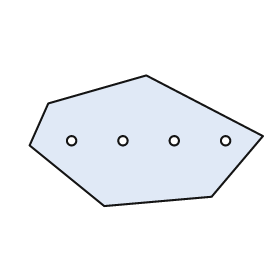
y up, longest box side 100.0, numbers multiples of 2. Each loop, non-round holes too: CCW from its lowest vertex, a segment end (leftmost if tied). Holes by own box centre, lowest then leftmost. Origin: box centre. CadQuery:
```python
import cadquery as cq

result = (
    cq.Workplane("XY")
    .moveTo(-18.0, -28.0)
    .lineTo(28.0, -24.0)
    .lineTo(50.0, 2.0)
    .lineTo(0.0, 28.0)
    .lineTo(-42.0, 16.0)
    .lineTo(-50.0, -2.0)
    .close()
    .moveTo(-32.0, 0.0)
    .circle(2.0)
    .moveTo(-10.0, 0.0)
    .circle(2.0)
    .moveTo(12.0, 0.0)
    .circle(2.0)
    .moveTo(34.0, 0.0)
    .circle(2.0)
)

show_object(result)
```